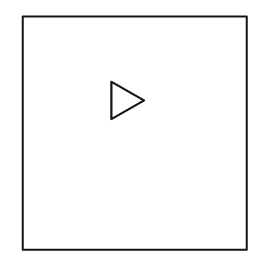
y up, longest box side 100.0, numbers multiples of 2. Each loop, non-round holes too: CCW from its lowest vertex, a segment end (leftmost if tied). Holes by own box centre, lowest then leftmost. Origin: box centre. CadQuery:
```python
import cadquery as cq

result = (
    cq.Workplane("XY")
    .moveTo(-48.0, -50.0)
    .lineTo(48.0, -50.0)
    .lineTo(48.0, 50.0)
    .lineTo(-48.0, 50.0)
    .close()
    .moveTo(-10.0, 6.0)
    .lineTo(4.0, 14.0)
    .lineTo(-10.0, 22.0)
    .close()
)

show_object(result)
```